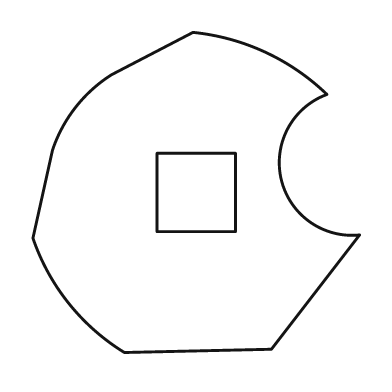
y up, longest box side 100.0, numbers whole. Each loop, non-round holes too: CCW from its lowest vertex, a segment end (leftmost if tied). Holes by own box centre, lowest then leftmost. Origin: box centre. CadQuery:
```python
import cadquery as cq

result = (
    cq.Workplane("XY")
    .moveTo(-22.0, -49.0)
    .lineTo(23.0, -48.0)
    .lineTo(50.0, -13.0)
    .threePointArc((26.0, 4.0), (40.0, 30.0))
    .threePointArc((21.0, 43.0), (-1.0, 49.0))
    .lineTo(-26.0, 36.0)
    .threePointArc((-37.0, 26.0), (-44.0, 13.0))
    .lineTo(-50.0, -14.0)
    .threePointArc((-39.0, -34.0), (-22.0, -49.0))
    .close()
    .moveTo(-12.0, -12.0)
    .lineTo(12.0, -12.0)
    .lineTo(12.0, 12.0)
    .lineTo(-12.0, 12.0)
    .close()
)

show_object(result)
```